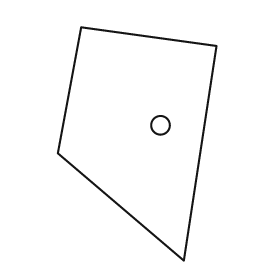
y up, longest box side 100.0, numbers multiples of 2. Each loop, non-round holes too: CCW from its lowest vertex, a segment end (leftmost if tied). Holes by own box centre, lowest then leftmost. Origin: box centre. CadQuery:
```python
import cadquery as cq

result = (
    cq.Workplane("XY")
    .moveTo(20.0, -50.0)
    .lineTo(34.0, 42.0)
    .lineTo(-24.0, 50.0)
    .lineTo(-34.0, -4.0)
    .close()
    .moveTo(10.0, 8.0)
    .circle(4.0)
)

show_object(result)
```